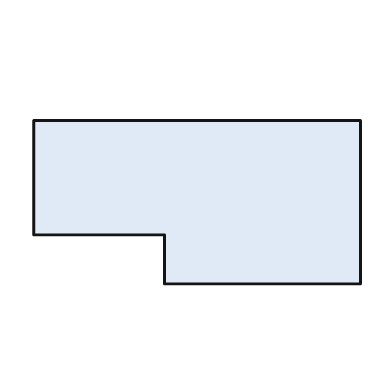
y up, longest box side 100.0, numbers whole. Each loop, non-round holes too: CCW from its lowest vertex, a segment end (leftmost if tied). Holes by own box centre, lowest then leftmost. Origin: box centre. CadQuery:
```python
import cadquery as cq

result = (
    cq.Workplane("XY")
    .moveTo(-10.0, -25.0)
    .lineTo(50.0, -25.0)
    .lineTo(50.0, 25.0)
    .lineTo(-50.0, 25.0)
    .lineTo(-50.0, -10.0)
    .lineTo(-10.0, -10.0)
    .close()
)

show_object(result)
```